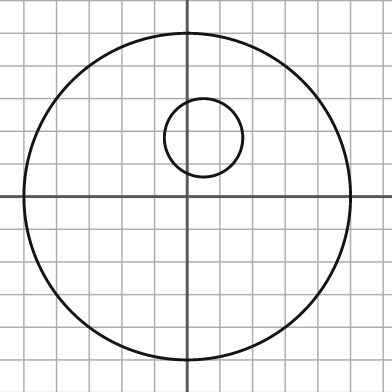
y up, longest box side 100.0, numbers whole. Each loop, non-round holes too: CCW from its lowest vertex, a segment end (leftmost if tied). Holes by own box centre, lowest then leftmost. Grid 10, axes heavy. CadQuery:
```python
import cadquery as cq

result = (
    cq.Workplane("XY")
    .moveTo(0.0, 0.0)
    .circle(50.0)
    .moveTo(5.0, 18.0)
    .circle(12.0)
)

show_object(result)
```